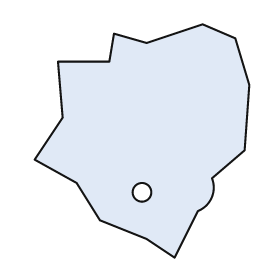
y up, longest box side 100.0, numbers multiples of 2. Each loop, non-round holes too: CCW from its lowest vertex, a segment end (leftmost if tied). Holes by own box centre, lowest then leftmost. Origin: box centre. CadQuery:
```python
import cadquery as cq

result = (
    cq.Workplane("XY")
    .moveTo(14.0, -50.0)
    .lineTo(24.0, -30.0)
    .threePointArc((30.0, -24.0), (30.0, -16.0))
    .lineTo(44.0, -4.0)
    .lineTo(46.0, 24.0)
    .lineTo(40.0, 44.0)
    .lineTo(26.0, 50.0)
    .lineTo(2.0, 42.0)
    .lineTo(-12.0, 46.0)
    .lineTo(-14.0, 34.0)
    .lineTo(-36.0, 34.0)
    .lineTo(-34.0, 10.0)
    .lineTo(-46.0, -8.0)
    .lineTo(-28.0, -18.0)
    .lineTo(-18.0, -34.0)
    .lineTo(2.0, -42.0)
    .close()
    .moveTo(0.0, -22.0)
    .circle(4.0)
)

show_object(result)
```